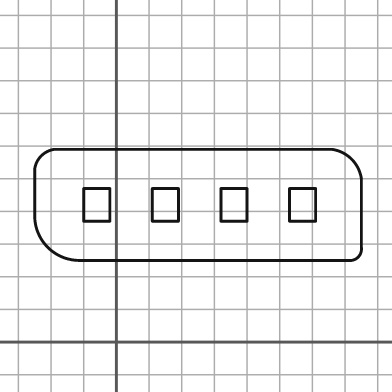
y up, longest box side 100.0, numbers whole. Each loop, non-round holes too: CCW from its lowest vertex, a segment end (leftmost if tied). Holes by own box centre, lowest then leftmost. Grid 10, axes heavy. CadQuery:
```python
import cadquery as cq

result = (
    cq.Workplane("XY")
    .moveTo(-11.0, 25.0)
    .lineTo(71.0, 25.0)
    .threePointArc((74.0, 26.0), (75.0, 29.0))
    .lineTo(75.0, 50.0)
    .threePointArc((72.0, 56.0), (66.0, 59.0))
    .lineTo(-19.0, 59.0)
    .threePointArc((-23.0, 57.0), (-25.0, 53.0))
    .lineTo(-25.0, 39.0)
    .threePointArc((-21.0, 29.0), (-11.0, 25.0))
    .close()
    .moveTo(-10.0, 37.0)
    .lineTo(-2.0, 37.0)
    .lineTo(-2.0, 47.0)
    .lineTo(-10.0, 47.0)
    .close()
    .moveTo(11.0, 37.0)
    .lineTo(19.0, 37.0)
    .lineTo(19.0, 47.0)
    .lineTo(11.0, 47.0)
    .close()
    .moveTo(32.0, 37.0)
    .lineTo(40.0, 37.0)
    .lineTo(40.0, 47.0)
    .lineTo(32.0, 47.0)
    .close()
    .moveTo(53.0, 37.0)
    .lineTo(61.0, 37.0)
    .lineTo(61.0, 47.0)
    .lineTo(53.0, 47.0)
    .close()
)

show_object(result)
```